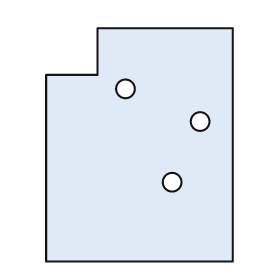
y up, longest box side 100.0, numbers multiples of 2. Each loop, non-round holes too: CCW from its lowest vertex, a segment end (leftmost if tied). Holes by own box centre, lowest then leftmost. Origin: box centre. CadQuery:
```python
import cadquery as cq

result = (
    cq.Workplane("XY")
    .moveTo(-40.0, -50.0)
    .lineTo(40.0, -50.0)
    .lineTo(40.0, 50.0)
    .lineTo(-18.0, 50.0)
    .lineTo(-18.0, 30.0)
    .lineTo(-40.0, 30.0)
    .close()
    .moveTo(14.0, -16.0)
    .circle(4.0)
    .moveTo(26.0, 10.0)
    .circle(4.0)
    .moveTo(-6.0, 24.0)
    .circle(4.0)
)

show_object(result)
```